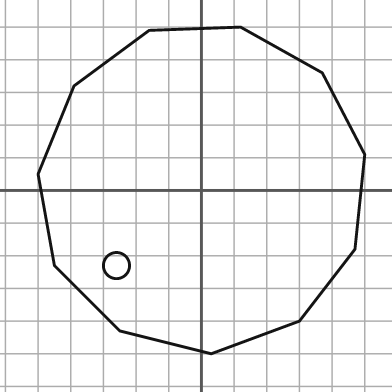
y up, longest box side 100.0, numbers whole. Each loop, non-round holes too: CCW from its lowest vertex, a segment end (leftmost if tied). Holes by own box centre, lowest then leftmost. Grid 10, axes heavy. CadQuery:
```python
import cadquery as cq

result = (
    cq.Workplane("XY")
    .moveTo(3.0, -50.0)
    .lineTo(30.0, -40.0)
    .lineTo(47.0, -18.0)
    .lineTo(50.0, 11.0)
    .lineTo(37.0, 36.0)
    .lineTo(12.0, 50.0)
    .lineTo(-16.0, 49.0)
    .lineTo(-39.0, 32.0)
    .lineTo(-50.0, 5.0)
    .lineTo(-45.0, -23.0)
    .lineTo(-25.0, -43.0)
    .close()
    .moveTo(-26.0, -23.0)
    .circle(4.0)
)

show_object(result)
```